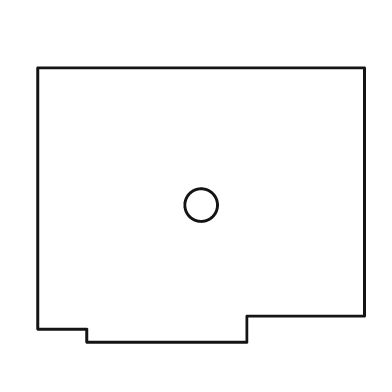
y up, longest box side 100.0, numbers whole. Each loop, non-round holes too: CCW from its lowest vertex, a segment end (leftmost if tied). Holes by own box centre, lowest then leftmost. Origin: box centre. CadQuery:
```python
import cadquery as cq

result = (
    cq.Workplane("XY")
    .moveTo(-35.0, -42.0)
    .lineTo(14.0, -42.0)
    .lineTo(14.0, -34.0)
    .lineTo(50.0, -34.0)
    .lineTo(50.0, 42.0)
    .lineTo(-50.0, 42.0)
    .lineTo(-50.0, -38.0)
    .lineTo(-35.0, -38.0)
    .close()
    .moveTo(0.0, 0.0)
    .circle(5.0)
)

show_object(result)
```